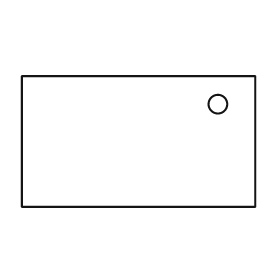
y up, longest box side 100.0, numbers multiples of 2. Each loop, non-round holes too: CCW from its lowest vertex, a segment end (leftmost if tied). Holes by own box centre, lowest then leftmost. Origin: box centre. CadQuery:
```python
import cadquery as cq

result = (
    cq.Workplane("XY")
    .moveTo(-50.0, -28.0)
    .lineTo(50.0, -28.0)
    .lineTo(50.0, 28.0)
    .lineTo(-50.0, 28.0)
    .close()
    .moveTo(34.0, 16.0)
    .circle(4.0)
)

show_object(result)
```